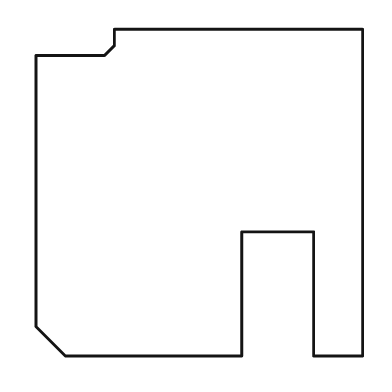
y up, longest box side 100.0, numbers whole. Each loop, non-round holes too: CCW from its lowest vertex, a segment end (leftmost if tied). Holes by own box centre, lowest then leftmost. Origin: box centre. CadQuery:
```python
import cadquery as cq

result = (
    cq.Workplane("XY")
    .moveTo(-41.0, -50.0)
    .lineTo(13.0, -50.0)
    .lineTo(13.0, -12.0)
    .lineTo(35.0, -12.0)
    .lineTo(35.0, -50.0)
    .lineTo(50.0, -50.0)
    .lineTo(50.0, 50.0)
    .lineTo(-26.0, 50.0)
    .lineTo(-26.0, 45.0)
    .lineTo(-29.0, 42.0)
    .lineTo(-50.0, 42.0)
    .lineTo(-50.0, -41.0)
    .close()
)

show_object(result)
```